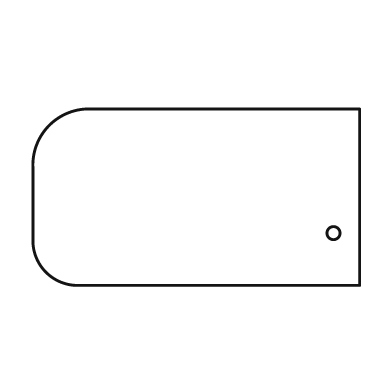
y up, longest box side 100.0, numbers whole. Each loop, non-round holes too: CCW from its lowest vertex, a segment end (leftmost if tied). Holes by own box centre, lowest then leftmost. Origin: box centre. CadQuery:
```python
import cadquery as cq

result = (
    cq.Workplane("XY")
    .moveTo(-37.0, -27.0)
    .lineTo(50.0, -27.0)
    .lineTo(50.0, 27.0)
    .lineTo(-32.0, 27.0)
    .threePointArc((-45.0, 22.0), (-50.0, 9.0))
    .lineTo(-50.0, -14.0)
    .threePointArc((-46.0, -23.0), (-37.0, -27.0))
    .close()
    .moveTo(42.0, -11.0)
    .circle(2.0)
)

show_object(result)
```